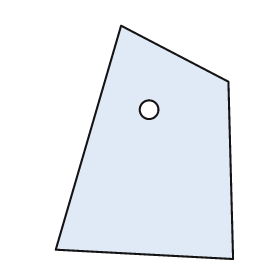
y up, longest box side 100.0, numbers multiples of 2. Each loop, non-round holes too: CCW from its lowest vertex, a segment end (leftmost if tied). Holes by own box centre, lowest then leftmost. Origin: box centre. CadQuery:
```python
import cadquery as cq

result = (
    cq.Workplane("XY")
    .moveTo(38.0, -50.0)
    .lineTo(36.0, 26.0)
    .lineTo(-10.0, 50.0)
    .lineTo(-38.0, -46.0)
    .close()
    .moveTo(2.0, 14.0)
    .circle(4.0)
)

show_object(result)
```